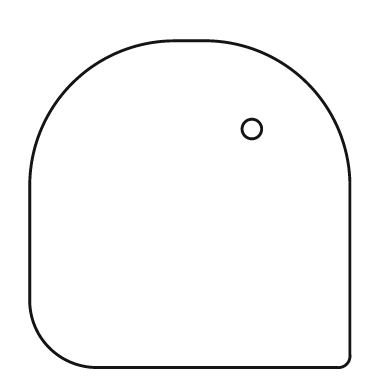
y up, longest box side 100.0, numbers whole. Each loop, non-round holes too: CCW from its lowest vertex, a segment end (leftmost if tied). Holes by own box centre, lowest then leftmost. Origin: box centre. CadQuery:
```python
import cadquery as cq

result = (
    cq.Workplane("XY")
    .moveTo(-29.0, -50.0)
    .lineTo(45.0, -50.0)
    .threePointArc((48.0, -49.0), (49.0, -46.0))
    .lineTo(49.0, 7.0)
    .threePointArc((36.0, 37.0), (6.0, 50.0))
    .lineTo(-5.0, 50.0)
    .threePointArc((-36.0, 37.0), (-49.0, 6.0))
    .lineTo(-49.0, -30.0)
    .threePointArc((-43.0, -44.0), (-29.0, -50.0))
    .close()
    .moveTo(19.0, 23.0)
    .circle(3.0)
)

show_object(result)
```